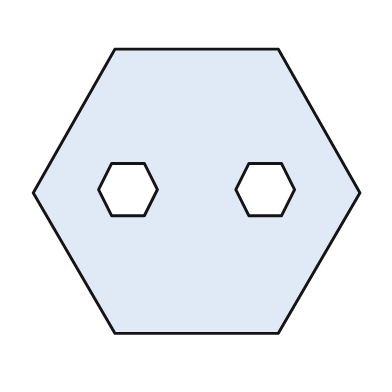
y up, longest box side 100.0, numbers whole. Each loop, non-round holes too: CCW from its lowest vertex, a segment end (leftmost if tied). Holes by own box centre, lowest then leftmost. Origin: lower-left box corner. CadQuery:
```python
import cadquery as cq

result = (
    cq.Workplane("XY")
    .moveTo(25.0, 0.0)
    .lineTo(75.0, 0.0)
    .lineTo(100.0, 43.0)
    .lineTo(75.0, 87.0)
    .lineTo(25.0, 87.0)
    .lineTo(0.0, 43.0)
    .close()
    .moveTo(24.0, 36.0)
    .lineTo(34.0, 36.0)
    .lineTo(38.0, 44.0)
    .lineTo(34.0, 52.0)
    .lineTo(24.0, 52.0)
    .lineTo(20.0, 44.0)
    .close()
    .moveTo(66.0, 36.0)
    .lineTo(76.0, 36.0)
    .lineTo(80.0, 44.0)
    .lineTo(76.0, 52.0)
    .lineTo(66.0, 52.0)
    .lineTo(62.0, 44.0)
    .close()
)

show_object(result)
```